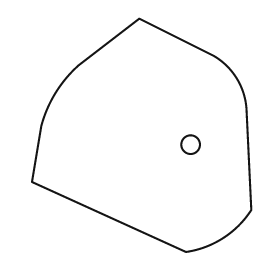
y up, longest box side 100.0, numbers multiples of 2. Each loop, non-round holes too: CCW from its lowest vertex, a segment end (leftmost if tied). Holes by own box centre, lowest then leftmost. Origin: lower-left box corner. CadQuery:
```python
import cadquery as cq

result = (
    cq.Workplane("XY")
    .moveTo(66.0, 0.0)
    .threePointArc((82.0, 6.0), (94.0, 18.0))
    .lineTo(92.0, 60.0)
    .threePointArc((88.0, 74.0), (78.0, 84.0))
    .lineTo(46.0, 100.0)
    .lineTo(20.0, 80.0)
    .threePointArc((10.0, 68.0), (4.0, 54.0))
    .lineTo(0.0, 30.0)
    .close()
    .moveTo(68.0, 46.0)
    .circle(4.0)
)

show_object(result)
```